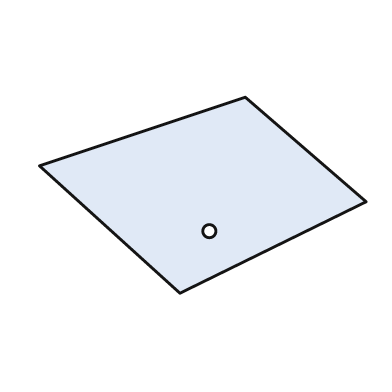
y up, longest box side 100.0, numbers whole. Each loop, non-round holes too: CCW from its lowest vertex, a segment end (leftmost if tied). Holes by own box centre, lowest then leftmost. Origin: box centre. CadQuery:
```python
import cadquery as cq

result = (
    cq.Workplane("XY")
    .moveTo(-7.0, -30.0)
    .lineTo(50.0, -2.0)
    .lineTo(13.0, 30.0)
    .lineTo(-50.0, 9.0)
    .close()
    .moveTo(2.0, -11.0)
    .circle(2.0)
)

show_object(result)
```